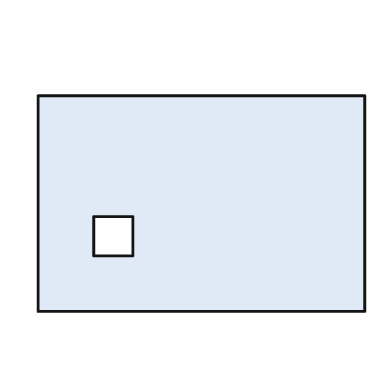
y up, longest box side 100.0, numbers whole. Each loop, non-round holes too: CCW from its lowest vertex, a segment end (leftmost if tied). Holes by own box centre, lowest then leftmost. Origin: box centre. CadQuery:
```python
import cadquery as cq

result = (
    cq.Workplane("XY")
    .moveTo(-50.0, -33.0)
    .lineTo(50.0, -33.0)
    .lineTo(50.0, 33.0)
    .lineTo(-50.0, 33.0)
    .close()
    .moveTo(-33.0, -16.0)
    .lineTo(-21.0, -16.0)
    .lineTo(-21.0, -4.0)
    .lineTo(-33.0, -4.0)
    .close()
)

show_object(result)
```